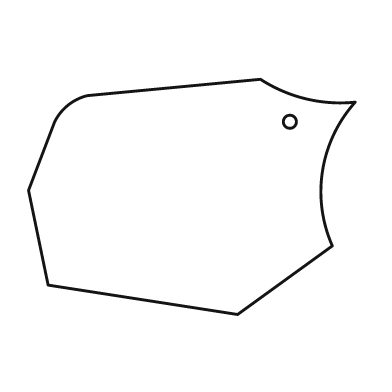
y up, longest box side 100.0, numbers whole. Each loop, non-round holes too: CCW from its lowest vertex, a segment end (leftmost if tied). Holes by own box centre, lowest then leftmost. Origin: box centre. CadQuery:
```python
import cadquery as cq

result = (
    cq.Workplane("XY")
    .moveTo(14.0, -36.0)
    .lineTo(43.0, -15.0)
    .threePointArc((40.0, 8.0), (50.0, 29.0))
    .threePointArc((35.0, 30.0), (21.0, 36.0))
    .lineTo(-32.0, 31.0)
    .threePointArc((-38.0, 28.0), (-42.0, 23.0))
    .lineTo(-50.0, 2.0)
    .lineTo(-44.0, -27.0)
    .close()
    .moveTo(30.0, 23.0)
    .circle(2.0)
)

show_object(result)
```